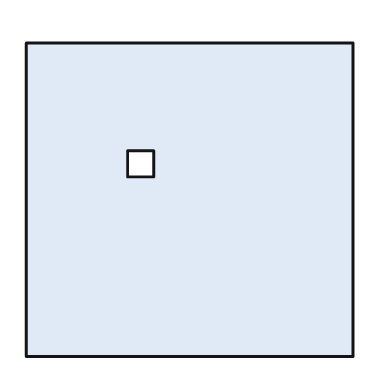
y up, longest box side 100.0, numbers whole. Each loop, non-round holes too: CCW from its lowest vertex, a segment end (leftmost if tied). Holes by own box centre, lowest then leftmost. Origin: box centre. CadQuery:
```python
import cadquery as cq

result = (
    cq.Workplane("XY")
    .moveTo(-50.0, -48.0)
    .lineTo(50.0, -48.0)
    .lineTo(50.0, 48.0)
    .lineTo(-50.0, 48.0)
    .close()
    .moveTo(-19.0, 7.0)
    .lineTo(-11.0, 7.0)
    .lineTo(-11.0, 15.0)
    .lineTo(-19.0, 15.0)
    .close()
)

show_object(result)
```